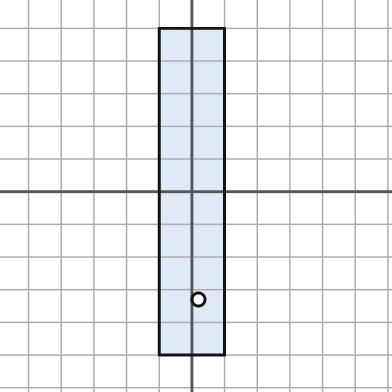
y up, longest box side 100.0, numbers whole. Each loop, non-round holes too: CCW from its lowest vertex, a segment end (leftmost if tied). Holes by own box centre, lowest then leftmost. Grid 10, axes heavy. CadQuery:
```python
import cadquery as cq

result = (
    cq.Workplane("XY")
    .moveTo(-10.0, -50.0)
    .lineTo(10.0, -50.0)
    .lineTo(10.0, 50.0)
    .lineTo(-10.0, 50.0)
    .close()
    .moveTo(2.0, -33.0)
    .circle(2.0)
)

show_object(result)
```